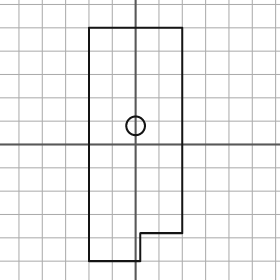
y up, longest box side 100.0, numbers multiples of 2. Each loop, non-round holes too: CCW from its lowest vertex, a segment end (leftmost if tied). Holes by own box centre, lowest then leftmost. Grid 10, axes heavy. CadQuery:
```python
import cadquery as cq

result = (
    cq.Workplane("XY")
    .moveTo(-20.0, -50.0)
    .lineTo(2.0, -50.0)
    .lineTo(2.0, -38.0)
    .lineTo(20.0, -38.0)
    .lineTo(20.0, 50.0)
    .lineTo(-20.0, 50.0)
    .close()
    .moveTo(0.0, 8.0)
    .circle(4.0)
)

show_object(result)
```